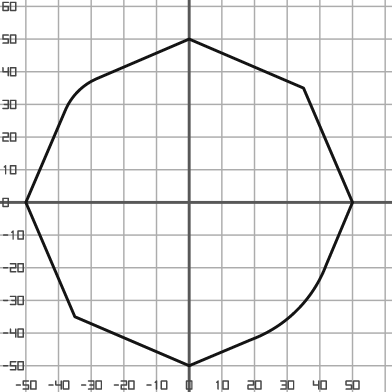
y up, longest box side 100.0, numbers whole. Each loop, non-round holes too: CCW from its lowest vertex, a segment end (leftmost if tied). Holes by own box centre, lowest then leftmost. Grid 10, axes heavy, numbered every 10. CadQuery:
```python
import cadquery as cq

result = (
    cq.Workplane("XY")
    .moveTo(0.0, -50.0)
    .lineTo(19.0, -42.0)
    .threePointArc((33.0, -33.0), (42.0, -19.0))
    .lineTo(50.0, 0.0)
    .lineTo(35.0, 35.0)
    .lineTo(0.0, 50.0)
    .lineTo(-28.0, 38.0)
    .threePointArc((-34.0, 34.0), (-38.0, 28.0))
    .lineTo(-50.0, 0.0)
    .lineTo(-35.0, -35.0)
    .close()
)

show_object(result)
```